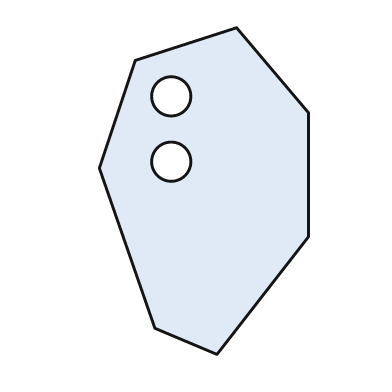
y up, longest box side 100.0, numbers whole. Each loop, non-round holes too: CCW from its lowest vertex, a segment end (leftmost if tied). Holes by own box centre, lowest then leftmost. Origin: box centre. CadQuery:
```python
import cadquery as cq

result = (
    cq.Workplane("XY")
    .moveTo(4.0, -50.0)
    .lineTo(32.0, -14.0)
    .lineTo(32.0, 24.0)
    .lineTo(10.0, 50.0)
    .lineTo(-21.0, 40.0)
    .lineTo(-32.0, 7.0)
    .lineTo(-15.0, -42.0)
    .close()
    .moveTo(-10.0, 9.0)
    .circle(6.0)
    .moveTo(-10.0, 29.0)
    .circle(6.0)
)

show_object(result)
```